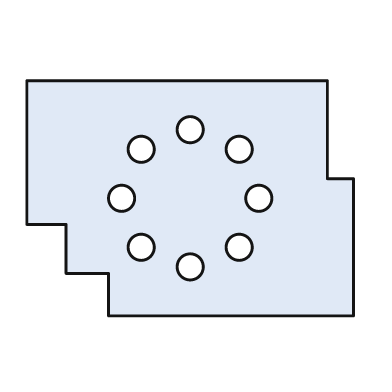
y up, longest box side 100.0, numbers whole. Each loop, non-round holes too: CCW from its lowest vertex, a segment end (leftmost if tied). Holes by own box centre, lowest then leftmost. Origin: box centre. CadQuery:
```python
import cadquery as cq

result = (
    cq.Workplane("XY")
    .moveTo(-25.0, -36.0)
    .lineTo(50.0, -36.0)
    .lineTo(50.0, 6.0)
    .lineTo(42.0, 6.0)
    .lineTo(42.0, 36.0)
    .lineTo(-50.0, 36.0)
    .lineTo(-50.0, -8.0)
    .lineTo(-38.0, -8.0)
    .lineTo(-38.0, -23.0)
    .lineTo(-25.0, -23.0)
    .close()
    .moveTo(0.0, -21.0)
    .circle(4.0)
    .moveTo(-15.0, -15.0)
    .circle(4.0)
    .moveTo(15.0, -15.0)
    .circle(4.0)
    .moveTo(-21.0, 0.0)
    .circle(4.0)
    .moveTo(21.0, 0.0)
    .circle(4.0)
    .moveTo(-15.0, 15.0)
    .circle(4.0)
    .moveTo(15.0, 15.0)
    .circle(4.0)
    .moveTo(0.0, 21.0)
    .circle(4.0)
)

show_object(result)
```